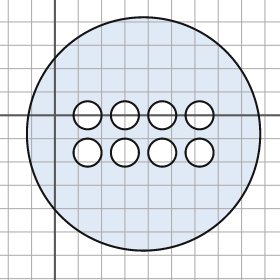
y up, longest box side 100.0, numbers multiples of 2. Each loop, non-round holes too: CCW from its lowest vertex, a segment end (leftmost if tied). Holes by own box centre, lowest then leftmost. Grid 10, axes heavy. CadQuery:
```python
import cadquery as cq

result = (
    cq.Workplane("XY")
    .moveTo(38.0, -8.0)
    .circle(50.0)
    .moveTo(14.0, -16.0)
    .circle(6.0)
    .moveTo(30.0, -16.0)
    .circle(6.0)
    .moveTo(46.0, -16.0)
    .circle(6.0)
    .moveTo(62.0, -16.0)
    .circle(6.0)
    .moveTo(14.0, 0.0)
    .circle(6.0)
    .moveTo(30.0, 0.0)
    .circle(6.0)
    .moveTo(46.0, 0.0)
    .circle(6.0)
    .moveTo(62.0, 0.0)
    .circle(6.0)
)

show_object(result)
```